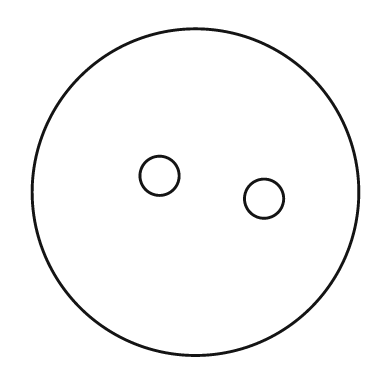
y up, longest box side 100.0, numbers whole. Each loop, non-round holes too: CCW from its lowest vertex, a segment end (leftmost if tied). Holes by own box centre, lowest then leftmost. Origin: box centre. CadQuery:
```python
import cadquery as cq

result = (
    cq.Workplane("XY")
    .moveTo(0.0, 0.0)
    .circle(50.0)
    .moveTo(21.0, -2.0)
    .circle(6.0)
    .moveTo(-11.0, 5.0)
    .circle(6.0)
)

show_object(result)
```